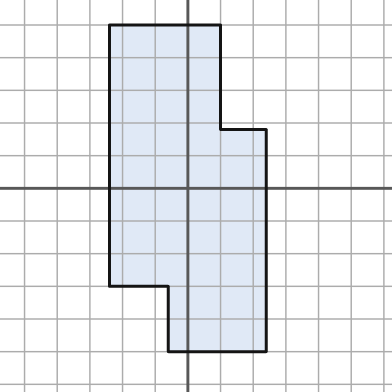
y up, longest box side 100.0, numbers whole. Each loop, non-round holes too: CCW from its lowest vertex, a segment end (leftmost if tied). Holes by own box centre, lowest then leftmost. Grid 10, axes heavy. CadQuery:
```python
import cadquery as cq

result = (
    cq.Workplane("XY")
    .moveTo(-6.0, -50.0)
    .lineTo(24.0, -50.0)
    .lineTo(24.0, 18.0)
    .lineTo(10.0, 18.0)
    .lineTo(10.0, 50.0)
    .lineTo(-24.0, 50.0)
    .lineTo(-24.0, -30.0)
    .lineTo(-6.0, -30.0)
    .close()
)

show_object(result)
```